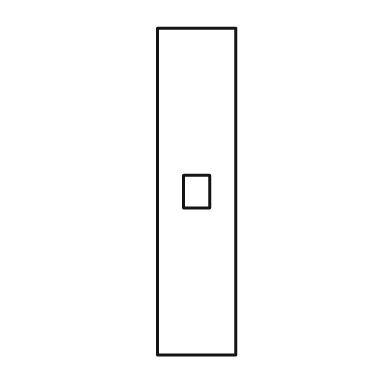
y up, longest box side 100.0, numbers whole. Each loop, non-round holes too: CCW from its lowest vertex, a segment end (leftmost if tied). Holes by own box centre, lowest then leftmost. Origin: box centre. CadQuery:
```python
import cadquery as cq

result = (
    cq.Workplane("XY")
    .moveTo(-12.0, -50.0)
    .lineTo(12.0, -50.0)
    .lineTo(12.0, 50.0)
    .lineTo(-12.0, 50.0)
    .close()
    .moveTo(-4.0, -5.0)
    .lineTo(4.0, -5.0)
    .lineTo(4.0, 5.0)
    .lineTo(-4.0, 5.0)
    .close()
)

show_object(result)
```